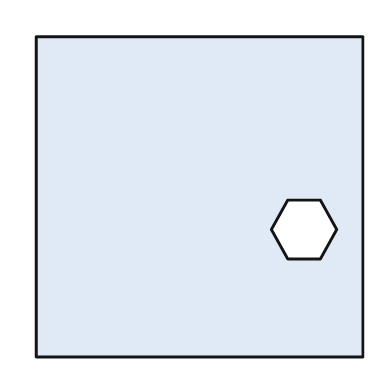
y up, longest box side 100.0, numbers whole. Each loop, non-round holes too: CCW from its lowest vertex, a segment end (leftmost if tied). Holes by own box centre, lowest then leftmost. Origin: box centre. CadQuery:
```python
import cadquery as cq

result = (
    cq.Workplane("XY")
    .moveTo(-50.0, -49.0)
    .lineTo(50.0, -49.0)
    .lineTo(50.0, 49.0)
    .lineTo(-50.0, 49.0)
    .close()
    .moveTo(27.0, -19.0)
    .lineTo(37.0, -19.0)
    .lineTo(42.0, -10.0)
    .lineTo(37.0, -1.0)
    .lineTo(27.0, -1.0)
    .lineTo(22.0, -10.0)
    .close()
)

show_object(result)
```